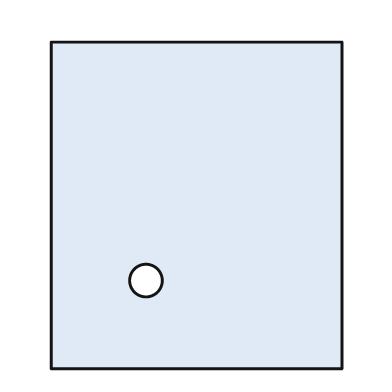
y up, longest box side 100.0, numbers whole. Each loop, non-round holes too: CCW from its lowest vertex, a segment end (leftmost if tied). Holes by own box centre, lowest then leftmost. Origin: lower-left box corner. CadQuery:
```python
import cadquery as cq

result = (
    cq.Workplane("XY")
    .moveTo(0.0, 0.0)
    .lineTo(89.0, 0.0)
    .lineTo(89.0, 100.0)
    .lineTo(0.0, 100.0)
    .close()
    .moveTo(29.0, 27.0)
    .circle(5.0)
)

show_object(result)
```